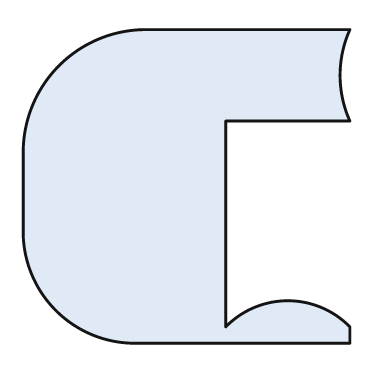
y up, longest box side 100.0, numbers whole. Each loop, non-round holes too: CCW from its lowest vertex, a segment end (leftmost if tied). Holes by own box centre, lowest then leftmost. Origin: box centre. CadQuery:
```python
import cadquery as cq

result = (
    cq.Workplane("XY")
    .moveTo(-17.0, -48.0)
    .lineTo(50.0, -48.0)
    .lineTo(50.0, -43.0)
    .threePointArc((31.0, -35.0), (12.0, -43.0))
    .lineTo(12.0, 20.0)
    .lineTo(50.0, 20.0)
    .threePointArc((47.0, 34.0), (50.0, 48.0))
    .lineTo(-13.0, 48.0)
    .threePointArc((-39.0, 37.0), (-50.0, 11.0))
    .lineTo(-50.0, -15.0)
    .threePointArc((-40.0, -38.0), (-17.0, -48.0))
    .close()
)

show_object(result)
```